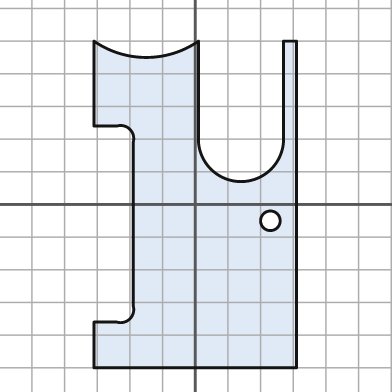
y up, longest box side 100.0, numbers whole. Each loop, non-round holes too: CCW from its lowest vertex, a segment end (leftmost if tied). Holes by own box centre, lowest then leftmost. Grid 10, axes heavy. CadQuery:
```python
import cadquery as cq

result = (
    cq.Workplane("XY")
    .moveTo(-31.0, -50.0)
    .lineTo(31.0, -50.0)
    .lineTo(31.0, 50.0)
    .lineTo(27.0, 50.0)
    .lineTo(27.0, 19.0)
    .threePointArc((14.0, 7.0), (1.0, 19.0))
    .lineTo(1.0, 50.0)
    .threePointArc((-15.0, 45.0), (-31.0, 50.0))
    .lineTo(-31.0, 24.0)
    .lineTo(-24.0, 24.0)
    .threePointArc((-20.0, 23.0), (-19.0, 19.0))
    .lineTo(-19.0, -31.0)
    .threePointArc((-20.0, -35.0), (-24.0, -36.0))
    .lineTo(-31.0, -36.0)
    .close()
    .moveTo(23.0, -5.0)
    .circle(3.0)
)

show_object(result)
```